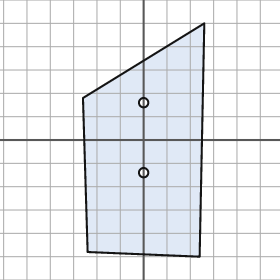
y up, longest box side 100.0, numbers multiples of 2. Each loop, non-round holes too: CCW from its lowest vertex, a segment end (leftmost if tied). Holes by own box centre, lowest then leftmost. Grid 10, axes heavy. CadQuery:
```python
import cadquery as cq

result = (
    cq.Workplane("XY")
    .moveTo(24.0, -50.0)
    .lineTo(26.0, 50.0)
    .lineTo(-26.0, 18.0)
    .lineTo(-24.0, -48.0)
    .close()
    .moveTo(0.0, -14.0)
    .circle(2.0)
    .moveTo(0.0, 16.0)
    .circle(2.0)
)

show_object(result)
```